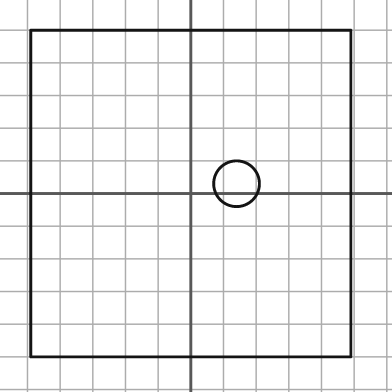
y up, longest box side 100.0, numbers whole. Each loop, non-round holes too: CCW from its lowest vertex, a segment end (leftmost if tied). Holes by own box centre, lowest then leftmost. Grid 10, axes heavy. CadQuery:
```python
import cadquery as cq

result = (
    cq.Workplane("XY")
    .moveTo(-49.0, -50.0)
    .lineTo(49.0, -50.0)
    .lineTo(49.0, 50.0)
    .lineTo(-49.0, 50.0)
    .close()
    .moveTo(14.0, 3.0)
    .circle(7.0)
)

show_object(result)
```